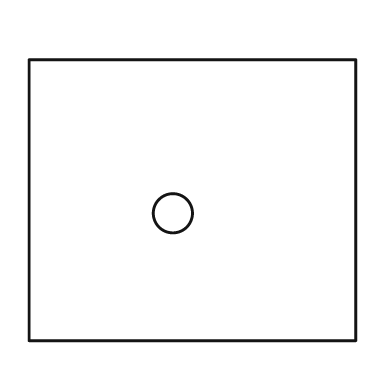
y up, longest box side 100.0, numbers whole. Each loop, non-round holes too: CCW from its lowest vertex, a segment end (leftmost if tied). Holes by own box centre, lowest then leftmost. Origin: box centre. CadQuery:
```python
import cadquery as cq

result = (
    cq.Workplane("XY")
    .moveTo(-50.0, -43.0)
    .lineTo(50.0, -43.0)
    .lineTo(50.0, 43.0)
    .lineTo(-50.0, 43.0)
    .close()
    .moveTo(-6.0, -4.0)
    .circle(6.0)
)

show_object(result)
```